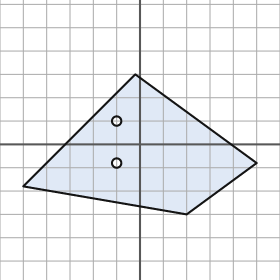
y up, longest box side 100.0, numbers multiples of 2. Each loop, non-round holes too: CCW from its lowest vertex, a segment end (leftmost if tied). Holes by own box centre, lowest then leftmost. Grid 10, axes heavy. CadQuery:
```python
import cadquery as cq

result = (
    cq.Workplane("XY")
    .moveTo(20.0, -30.0)
    .lineTo(50.0, -8.0)
    .lineTo(-2.0, 30.0)
    .lineTo(-50.0, -18.0)
    .close()
    .moveTo(-10.0, -8.0)
    .circle(2.0)
    .moveTo(-10.0, 10.0)
    .circle(2.0)
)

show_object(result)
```